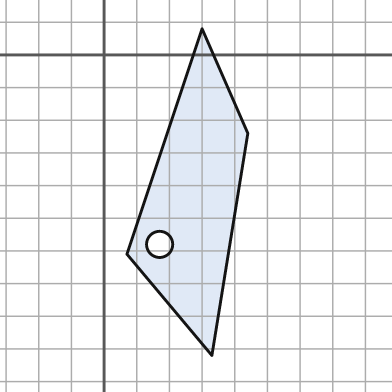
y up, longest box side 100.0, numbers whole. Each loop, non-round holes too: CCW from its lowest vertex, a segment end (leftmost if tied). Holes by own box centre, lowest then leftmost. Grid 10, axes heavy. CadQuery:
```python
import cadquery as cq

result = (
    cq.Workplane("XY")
    .moveTo(33.0, -92.0)
    .lineTo(44.0, -24.0)
    .lineTo(30.0, 8.0)
    .lineTo(7.0, -61.0)
    .close()
    .moveTo(17.0, -58.0)
    .circle(4.0)
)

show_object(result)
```